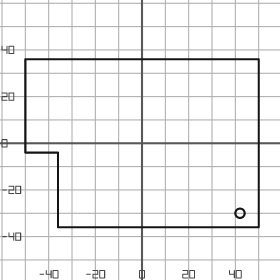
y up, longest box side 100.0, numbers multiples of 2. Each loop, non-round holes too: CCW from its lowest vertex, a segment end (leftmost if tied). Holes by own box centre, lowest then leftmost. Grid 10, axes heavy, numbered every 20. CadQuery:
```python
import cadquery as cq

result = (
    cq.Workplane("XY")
    .moveTo(-36.0, -36.0)
    .lineTo(50.0, -36.0)
    .lineTo(50.0, 36.0)
    .lineTo(-50.0, 36.0)
    .lineTo(-50.0, -4.0)
    .lineTo(-36.0, -4.0)
    .close()
    .moveTo(42.0, -30.0)
    .circle(2.0)
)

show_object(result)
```